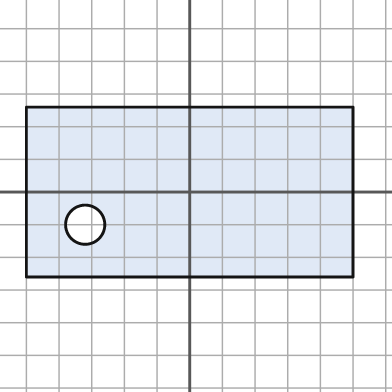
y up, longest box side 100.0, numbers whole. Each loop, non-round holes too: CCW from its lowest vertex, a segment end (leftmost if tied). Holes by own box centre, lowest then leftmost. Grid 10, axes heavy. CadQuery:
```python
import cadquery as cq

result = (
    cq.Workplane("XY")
    .moveTo(-50.0, -26.0)
    .lineTo(50.0, -26.0)
    .lineTo(50.0, 26.0)
    .lineTo(-50.0, 26.0)
    .close()
    .moveTo(-32.0, -10.0)
    .circle(6.0)
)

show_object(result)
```